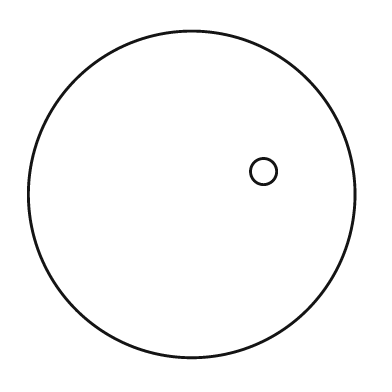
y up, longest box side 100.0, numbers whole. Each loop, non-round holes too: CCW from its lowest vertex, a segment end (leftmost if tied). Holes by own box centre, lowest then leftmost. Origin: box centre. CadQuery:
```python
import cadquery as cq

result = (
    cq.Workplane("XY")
    .moveTo(0.0, 0.0)
    .circle(50.0)
    .moveTo(22.0, 7.0)
    .circle(4.0)
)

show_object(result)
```